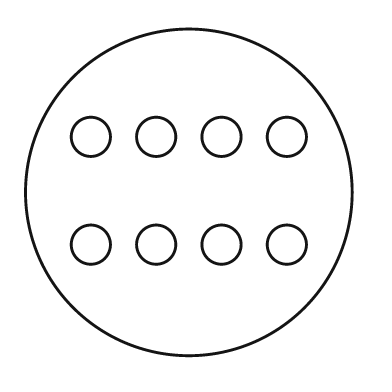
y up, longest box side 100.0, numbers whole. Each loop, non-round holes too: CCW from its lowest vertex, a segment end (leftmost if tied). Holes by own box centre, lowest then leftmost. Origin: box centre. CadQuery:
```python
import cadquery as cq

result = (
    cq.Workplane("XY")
    .moveTo(0.0, 0.0)
    .circle(50.0)
    .moveTo(-30.0, -16.0)
    .circle(6.0)
    .moveTo(-10.0, -16.0)
    .circle(6.0)
    .moveTo(10.0, -16.0)
    .circle(6.0)
    .moveTo(30.0, -16.0)
    .circle(6.0)
    .moveTo(-30.0, 17.0)
    .circle(6.0)
    .moveTo(-10.0, 17.0)
    .circle(6.0)
    .moveTo(10.0, 17.0)
    .circle(6.0)
    .moveTo(30.0, 17.0)
    .circle(6.0)
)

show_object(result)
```